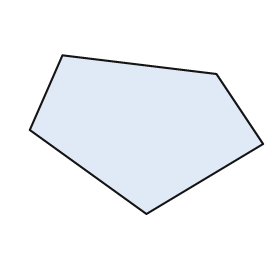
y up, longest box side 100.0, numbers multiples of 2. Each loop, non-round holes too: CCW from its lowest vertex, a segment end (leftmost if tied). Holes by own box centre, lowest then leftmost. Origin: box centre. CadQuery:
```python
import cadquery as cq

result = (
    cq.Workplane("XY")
    .moveTo(0.0, -34.0)
    .lineTo(50.0, -4.0)
    .lineTo(30.0, 26.0)
    .lineTo(-36.0, 34.0)
    .lineTo(-50.0, 2.0)
    .close()
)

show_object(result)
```